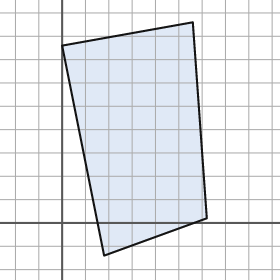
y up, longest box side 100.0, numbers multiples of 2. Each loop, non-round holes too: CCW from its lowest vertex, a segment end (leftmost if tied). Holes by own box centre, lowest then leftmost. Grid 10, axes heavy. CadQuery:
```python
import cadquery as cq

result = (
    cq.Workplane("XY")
    .moveTo(18.0, -14.0)
    .lineTo(62.0, 2.0)
    .lineTo(56.0, 86.0)
    .lineTo(0.0, 76.0)
    .close()
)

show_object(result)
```